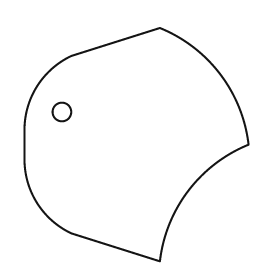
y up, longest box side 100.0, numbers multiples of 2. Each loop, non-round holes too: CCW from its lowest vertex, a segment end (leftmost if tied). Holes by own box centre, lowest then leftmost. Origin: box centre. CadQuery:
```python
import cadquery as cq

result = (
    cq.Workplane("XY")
    .moveTo(10.0, -50.0)
    .threePointArc((22.0, -20.0), (48.0, 0.0))
    .threePointArc((36.0, 30.0), (10.0, 50.0))
    .lineTo(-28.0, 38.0)
    .threePointArc((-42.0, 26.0), (-48.0, 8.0))
    .lineTo(-48.0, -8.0)
    .threePointArc((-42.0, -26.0), (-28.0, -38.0))
    .close()
    .moveTo(-32.0, 14.0)
    .circle(4.0)
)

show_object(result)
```